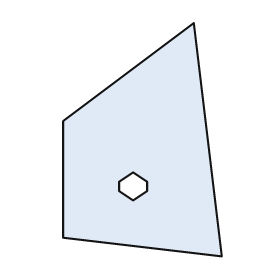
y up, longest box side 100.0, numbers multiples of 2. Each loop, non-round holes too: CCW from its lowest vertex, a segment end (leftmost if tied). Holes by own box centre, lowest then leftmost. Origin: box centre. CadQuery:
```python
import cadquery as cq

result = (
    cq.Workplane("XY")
    .moveTo(34.0, -50.0)
    .lineTo(22.0, 50.0)
    .lineTo(-34.0, 8.0)
    .lineTo(-34.0, -42.0)
    .close()
    .moveTo(-4.0, -26.0)
    .lineTo(2.0, -22.0)
    .lineTo(2.0, -18.0)
    .lineTo(-4.0, -14.0)
    .lineTo(-10.0, -18.0)
    .lineTo(-10.0, -22.0)
    .close()
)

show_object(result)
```